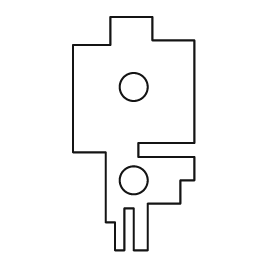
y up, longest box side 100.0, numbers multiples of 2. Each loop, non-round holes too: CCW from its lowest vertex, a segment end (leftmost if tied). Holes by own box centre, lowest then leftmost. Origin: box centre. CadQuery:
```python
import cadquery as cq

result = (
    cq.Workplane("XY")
    .moveTo(-8.0, -50.0)
    .lineTo(-4.0, -50.0)
    .lineTo(-4.0, -32.0)
    .lineTo(0.0, -32.0)
    .lineTo(0.0, -50.0)
    .lineTo(6.0, -50.0)
    .lineTo(6.0, -30.0)
    .lineTo(20.0, -30.0)
    .lineTo(20.0, -20.0)
    .lineTo(26.0, -20.0)
    .lineTo(26.0, -10.0)
    .lineTo(2.0, -10.0)
    .lineTo(2.0, -4.0)
    .lineTo(26.0, -4.0)
    .lineTo(26.0, 40.0)
    .lineTo(8.0, 40.0)
    .lineTo(8.0, 50.0)
    .lineTo(-10.0, 50.0)
    .lineTo(-10.0, 38.0)
    .lineTo(-26.0, 38.0)
    .lineTo(-26.0, -8.0)
    .lineTo(-12.0, -8.0)
    .lineTo(-12.0, -38.0)
    .lineTo(-8.0, -38.0)
    .close()
    .moveTo(0.0, -20.0)
    .circle(6.0)
    .moveTo(0.0, 20.0)
    .circle(6.0)
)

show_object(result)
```